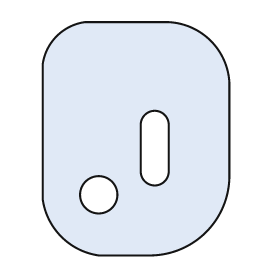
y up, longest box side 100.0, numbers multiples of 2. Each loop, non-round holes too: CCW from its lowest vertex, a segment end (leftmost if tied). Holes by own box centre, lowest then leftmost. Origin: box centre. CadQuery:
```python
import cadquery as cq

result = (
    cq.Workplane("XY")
    .moveTo(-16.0, -50.0)
    .lineTo(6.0, -50.0)
    .threePointArc((30.0, -40.0), (40.0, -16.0))
    .lineTo(40.0, 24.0)
    .threePointArc((32.0, 42.0), (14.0, 50.0))
    .lineTo(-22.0, 50.0)
    .threePointArc((-34.0, 44.0), (-40.0, 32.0))
    .lineTo(-40.0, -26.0)
    .threePointArc((-32.0, -42.0), (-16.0, -50.0))
    .close()
    .moveTo(-16.0, -24.0)
    .circle(8.0)
    .moveTo(2.0, -14.0)
    .threePointArc((8.0, -20.0), (14.0, -14.0))
    .lineTo(14.0, 6.0)
    .threePointArc((8.0, 12.0), (2.0, 6.0))
    .close()
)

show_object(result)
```